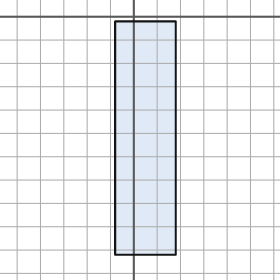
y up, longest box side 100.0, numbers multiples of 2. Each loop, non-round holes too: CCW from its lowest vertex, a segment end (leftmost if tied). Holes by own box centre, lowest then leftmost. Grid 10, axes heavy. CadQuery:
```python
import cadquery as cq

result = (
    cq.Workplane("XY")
    .moveTo(-8.0, -102.0)
    .lineTo(18.0, -102.0)
    .lineTo(18.0, -2.0)
    .lineTo(-8.0, -2.0)
    .close()
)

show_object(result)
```